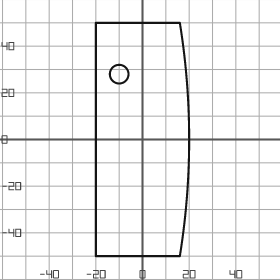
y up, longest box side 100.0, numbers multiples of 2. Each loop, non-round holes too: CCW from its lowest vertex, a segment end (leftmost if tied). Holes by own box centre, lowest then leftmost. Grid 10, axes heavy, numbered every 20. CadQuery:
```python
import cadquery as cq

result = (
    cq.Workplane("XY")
    .moveTo(-20.0, -50.0)
    .lineTo(16.0, -50.0)
    .threePointArc((20.0, 0.0), (16.0, 50.0))
    .lineTo(-20.0, 50.0)
    .close()
    .moveTo(-10.0, 28.0)
    .circle(4.0)
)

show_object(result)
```